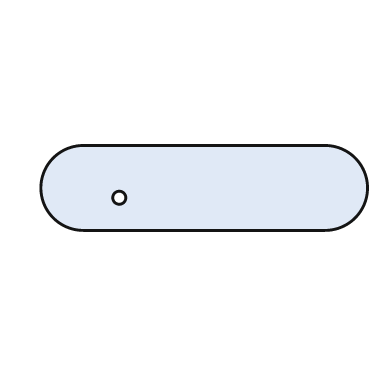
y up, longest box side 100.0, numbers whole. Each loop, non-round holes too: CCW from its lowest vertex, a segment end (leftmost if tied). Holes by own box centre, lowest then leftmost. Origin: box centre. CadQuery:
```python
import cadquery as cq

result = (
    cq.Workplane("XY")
    .moveTo(-37.0, -13.0)
    .lineTo(37.0, -13.0)
    .threePointArc((50.0, 0.0), (37.0, 13.0))
    .lineTo(-37.0, 13.0)
    .threePointArc((-50.0, 0.0), (-37.0, -13.0))
    .close()
    .moveTo(-26.0, -3.0)
    .circle(2.0)
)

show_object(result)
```